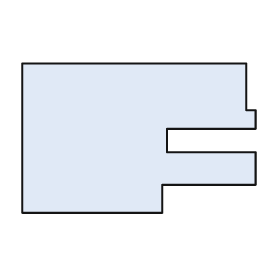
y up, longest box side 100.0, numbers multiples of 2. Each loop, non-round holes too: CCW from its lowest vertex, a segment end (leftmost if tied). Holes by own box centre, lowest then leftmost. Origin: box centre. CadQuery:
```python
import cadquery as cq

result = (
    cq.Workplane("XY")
    .moveTo(-50.0, -32.0)
    .lineTo(10.0, -32.0)
    .lineTo(10.0, -20.0)
    .lineTo(50.0, -20.0)
    .lineTo(50.0, -6.0)
    .lineTo(12.0, -6.0)
    .lineTo(12.0, 4.0)
    .lineTo(50.0, 4.0)
    .lineTo(50.0, 12.0)
    .lineTo(46.0, 12.0)
    .lineTo(46.0, 32.0)
    .lineTo(-50.0, 32.0)
    .close()
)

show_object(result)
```